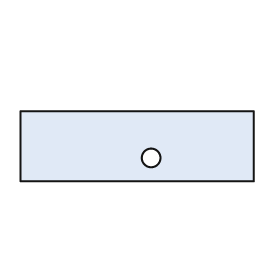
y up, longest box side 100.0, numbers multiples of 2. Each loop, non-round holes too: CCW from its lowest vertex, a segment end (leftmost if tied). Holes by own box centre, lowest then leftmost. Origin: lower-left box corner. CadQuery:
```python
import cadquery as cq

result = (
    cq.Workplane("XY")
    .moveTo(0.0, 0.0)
    .lineTo(100.0, 0.0)
    .lineTo(100.0, 30.0)
    .lineTo(0.0, 30.0)
    .close()
    .moveTo(56.0, 10.0)
    .circle(4.0)
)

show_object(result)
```